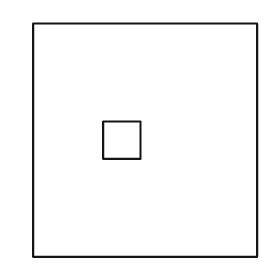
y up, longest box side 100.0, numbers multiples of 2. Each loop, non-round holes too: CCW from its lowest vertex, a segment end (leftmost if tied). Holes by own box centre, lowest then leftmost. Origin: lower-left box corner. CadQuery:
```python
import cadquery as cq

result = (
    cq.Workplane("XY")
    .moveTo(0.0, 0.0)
    .lineTo(96.0, 0.0)
    .lineTo(96.0, 100.0)
    .lineTo(0.0, 100.0)
    .close()
    .moveTo(30.0, 42.0)
    .lineTo(46.0, 42.0)
    .lineTo(46.0, 58.0)
    .lineTo(30.0, 58.0)
    .close()
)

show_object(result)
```